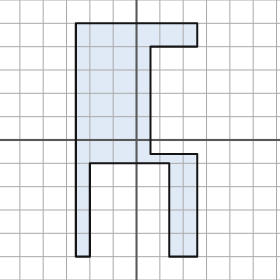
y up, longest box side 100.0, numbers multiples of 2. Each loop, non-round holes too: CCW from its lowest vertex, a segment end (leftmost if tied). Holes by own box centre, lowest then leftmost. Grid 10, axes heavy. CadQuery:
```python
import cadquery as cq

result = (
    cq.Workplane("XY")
    .moveTo(-26.0, -50.0)
    .lineTo(-20.0, -50.0)
    .lineTo(-20.0, -10.0)
    .lineTo(14.0, -10.0)
    .lineTo(14.0, -50.0)
    .lineTo(26.0, -50.0)
    .lineTo(26.0, -6.0)
    .lineTo(6.0, -6.0)
    .lineTo(6.0, 40.0)
    .lineTo(26.0, 40.0)
    .lineTo(26.0, 50.0)
    .lineTo(-26.0, 50.0)
    .close()
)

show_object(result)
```